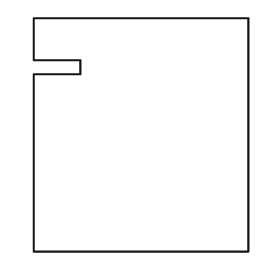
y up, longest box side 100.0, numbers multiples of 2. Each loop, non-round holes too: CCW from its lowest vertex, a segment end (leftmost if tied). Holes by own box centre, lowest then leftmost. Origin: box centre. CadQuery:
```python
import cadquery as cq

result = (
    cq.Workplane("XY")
    .moveTo(-46.0, -50.0)
    .lineTo(46.0, -50.0)
    .lineTo(46.0, 50.0)
    .lineTo(-46.0, 50.0)
    .lineTo(-46.0, 32.0)
    .lineTo(-26.0, 32.0)
    .lineTo(-26.0, 26.0)
    .lineTo(-46.0, 26.0)
    .close()
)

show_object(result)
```